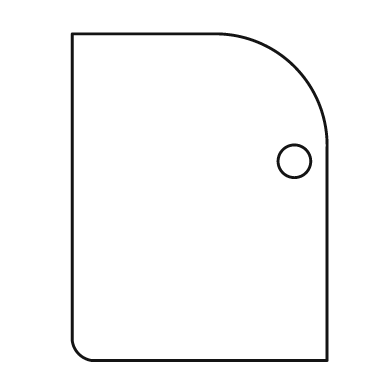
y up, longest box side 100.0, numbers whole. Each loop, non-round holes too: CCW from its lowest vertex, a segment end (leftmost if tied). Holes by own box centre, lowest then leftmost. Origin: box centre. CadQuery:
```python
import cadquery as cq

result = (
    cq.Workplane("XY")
    .moveTo(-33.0, -50.0)
    .lineTo(39.0, -50.0)
    .lineTo(39.0, 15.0)
    .threePointArc((29.0, 40.0), (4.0, 50.0))
    .lineTo(-39.0, 50.0)
    .lineTo(-39.0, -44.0)
    .threePointArc((-37.0, -48.0), (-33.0, -50.0))
    .close()
    .moveTo(29.0, 11.0)
    .circle(5.0)
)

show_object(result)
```